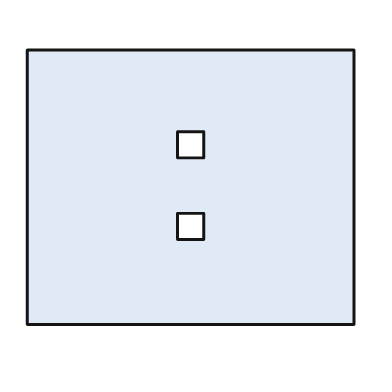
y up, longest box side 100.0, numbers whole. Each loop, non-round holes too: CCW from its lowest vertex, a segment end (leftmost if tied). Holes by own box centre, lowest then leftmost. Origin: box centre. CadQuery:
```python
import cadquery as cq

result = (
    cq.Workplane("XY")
    .moveTo(-50.0, -42.0)
    .lineTo(50.0, -42.0)
    .lineTo(50.0, 42.0)
    .lineTo(-50.0, 42.0)
    .close()
    .moveTo(-4.0, -16.0)
    .lineTo(4.0, -16.0)
    .lineTo(4.0, -8.0)
    .lineTo(-4.0, -8.0)
    .close()
    .moveTo(-4.0, 9.0)
    .lineTo(4.0, 9.0)
    .lineTo(4.0, 17.0)
    .lineTo(-4.0, 17.0)
    .close()
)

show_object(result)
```